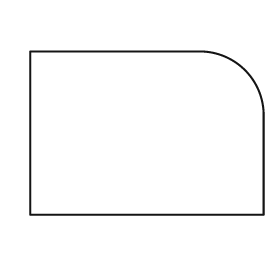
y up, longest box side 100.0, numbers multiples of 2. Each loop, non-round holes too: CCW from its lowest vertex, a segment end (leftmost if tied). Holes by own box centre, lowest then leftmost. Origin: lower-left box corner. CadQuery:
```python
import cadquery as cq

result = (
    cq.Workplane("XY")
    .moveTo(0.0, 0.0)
    .lineTo(100.0, 0.0)
    .lineTo(100.0, 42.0)
    .threePointArc((92.0, 62.0), (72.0, 70.0))
    .lineTo(0.0, 70.0)
    .close()
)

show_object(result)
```